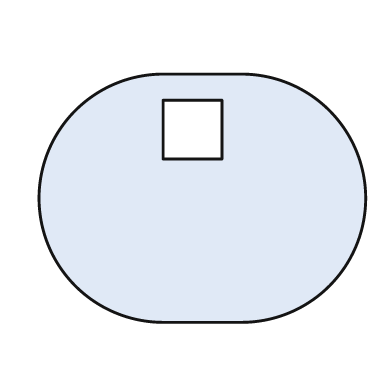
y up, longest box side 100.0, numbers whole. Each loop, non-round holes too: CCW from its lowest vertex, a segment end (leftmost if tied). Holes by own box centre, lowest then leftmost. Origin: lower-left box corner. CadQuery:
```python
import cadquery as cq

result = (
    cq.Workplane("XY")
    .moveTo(38.0, 0.0)
    .lineTo(62.0, 0.0)
    .threePointArc((100.0, 38.0), (62.0, 76.0))
    .lineTo(38.0, 76.0)
    .threePointArc((0.0, 38.0), (38.0, 0.0))
    .close()
    .moveTo(38.0, 50.0)
    .lineTo(56.0, 50.0)
    .lineTo(56.0, 68.0)
    .lineTo(38.0, 68.0)
    .close()
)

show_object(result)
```